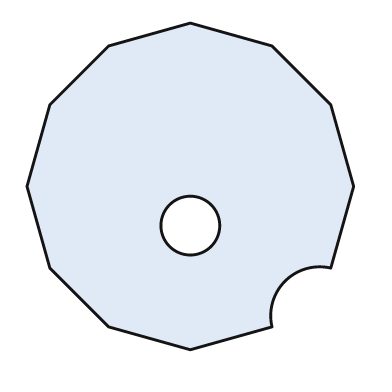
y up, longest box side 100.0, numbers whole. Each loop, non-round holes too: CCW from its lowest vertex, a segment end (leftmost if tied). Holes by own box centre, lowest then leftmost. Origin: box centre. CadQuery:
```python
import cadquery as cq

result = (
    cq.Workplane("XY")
    .moveTo(0.0, -50.0)
    .lineTo(25.0, -43.0)
    .threePointArc((29.0, -29.0), (43.0, -25.0))
    .lineTo(50.0, 0.0)
    .lineTo(43.0, 25.0)
    .lineTo(25.0, 43.0)
    .lineTo(0.0, 50.0)
    .lineTo(-25.0, 43.0)
    .lineTo(-43.0, 25.0)
    .lineTo(-50.0, 0.0)
    .lineTo(-43.0, -25.0)
    .lineTo(-25.0, -43.0)
    .close()
    .moveTo(0.0, -12.0)
    .circle(9.0)
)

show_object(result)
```